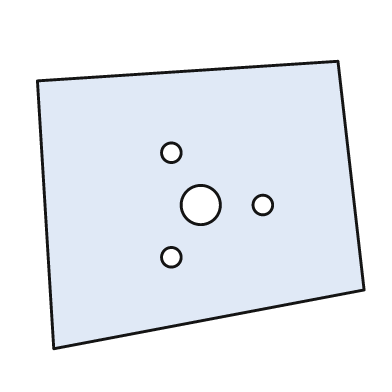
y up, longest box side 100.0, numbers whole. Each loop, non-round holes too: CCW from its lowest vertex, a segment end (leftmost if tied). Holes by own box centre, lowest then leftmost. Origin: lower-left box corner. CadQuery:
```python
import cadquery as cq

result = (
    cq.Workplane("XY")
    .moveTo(5.0, 0.0)
    .lineTo(100.0, 18.0)
    .lineTo(92.0, 88.0)
    .lineTo(0.0, 82.0)
    .close()
    .moveTo(41.0, 28.0)
    .circle(3.0)
    .moveTo(50.0, 44.0)
    .circle(6.0)
    .moveTo(69.0, 44.0)
    .circle(3.0)
    .moveTo(41.0, 60.0)
    .circle(3.0)
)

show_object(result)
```